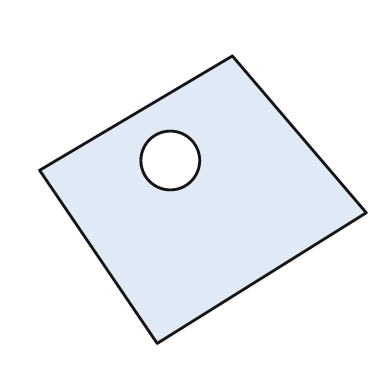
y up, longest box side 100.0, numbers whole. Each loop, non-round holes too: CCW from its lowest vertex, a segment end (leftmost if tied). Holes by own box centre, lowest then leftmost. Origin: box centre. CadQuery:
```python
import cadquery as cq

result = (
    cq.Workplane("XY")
    .moveTo(-14.0, -44.0)
    .lineTo(50.0, -4.0)
    .lineTo(9.0, 44.0)
    .lineTo(-50.0, 9.0)
    .close()
    .moveTo(-10.0, 12.0)
    .circle(9.0)
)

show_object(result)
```